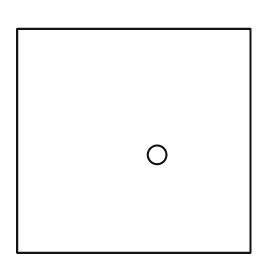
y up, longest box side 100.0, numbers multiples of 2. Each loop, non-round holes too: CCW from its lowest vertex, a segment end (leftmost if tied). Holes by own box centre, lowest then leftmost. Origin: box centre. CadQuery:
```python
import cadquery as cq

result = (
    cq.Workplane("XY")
    .moveTo(-50.0, -48.0)
    .lineTo(50.0, -48.0)
    .lineTo(50.0, 48.0)
    .lineTo(-50.0, 48.0)
    .close()
    .moveTo(10.0, -6.0)
    .circle(4.0)
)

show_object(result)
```